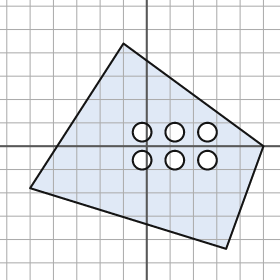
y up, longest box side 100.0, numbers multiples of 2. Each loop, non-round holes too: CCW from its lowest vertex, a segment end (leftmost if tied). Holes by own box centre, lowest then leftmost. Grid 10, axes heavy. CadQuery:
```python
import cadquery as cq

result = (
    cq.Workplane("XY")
    .moveTo(34.0, -44.0)
    .lineTo(50.0, 0.0)
    .lineTo(-10.0, 44.0)
    .lineTo(-50.0, -18.0)
    .close()
    .moveTo(-2.0, -6.0)
    .circle(4.0)
    .moveTo(12.0, -6.0)
    .circle(4.0)
    .moveTo(26.0, -6.0)
    .circle(4.0)
    .moveTo(-2.0, 6.0)
    .circle(4.0)
    .moveTo(12.0, 6.0)
    .circle(4.0)
    .moveTo(26.0, 6.0)
    .circle(4.0)
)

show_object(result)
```